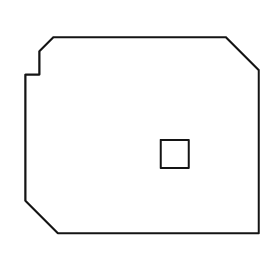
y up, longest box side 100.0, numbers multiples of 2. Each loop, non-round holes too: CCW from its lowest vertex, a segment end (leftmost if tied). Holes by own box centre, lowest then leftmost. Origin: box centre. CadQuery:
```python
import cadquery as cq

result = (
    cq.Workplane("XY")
    .moveTo(-36.0, -42.0)
    .lineTo(50.0, -42.0)
    .lineTo(50.0, 28.0)
    .lineTo(36.0, 42.0)
    .lineTo(-38.0, 42.0)
    .lineTo(-44.0, 36.0)
    .lineTo(-44.0, 26.0)
    .lineTo(-50.0, 26.0)
    .lineTo(-50.0, -28.0)
    .close()
    .moveTo(8.0, -14.0)
    .lineTo(20.0, -14.0)
    .lineTo(20.0, -2.0)
    .lineTo(8.0, -2.0)
    .close()
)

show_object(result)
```